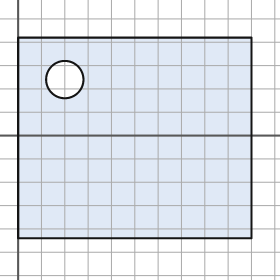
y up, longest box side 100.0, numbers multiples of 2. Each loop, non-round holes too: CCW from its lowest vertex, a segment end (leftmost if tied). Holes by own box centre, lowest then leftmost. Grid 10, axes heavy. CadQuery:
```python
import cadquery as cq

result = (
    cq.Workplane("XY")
    .moveTo(0.0, -44.0)
    .lineTo(100.0, -44.0)
    .lineTo(100.0, 42.0)
    .lineTo(0.0, 42.0)
    .close()
    .moveTo(20.0, 24.0)
    .circle(8.0)
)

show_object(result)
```